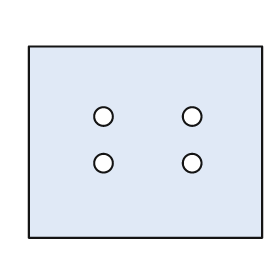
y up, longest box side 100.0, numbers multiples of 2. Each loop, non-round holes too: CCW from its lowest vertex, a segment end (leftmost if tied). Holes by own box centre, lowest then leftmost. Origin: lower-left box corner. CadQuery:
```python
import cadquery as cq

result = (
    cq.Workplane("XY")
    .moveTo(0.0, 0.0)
    .lineTo(100.0, 0.0)
    .lineTo(100.0, 82.0)
    .lineTo(0.0, 82.0)
    .close()
    .moveTo(32.0, 32.0)
    .circle(4.0)
    .moveTo(70.0, 32.0)
    .circle(4.0)
    .moveTo(32.0, 52.0)
    .circle(4.0)
    .moveTo(70.0, 52.0)
    .circle(4.0)
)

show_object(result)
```